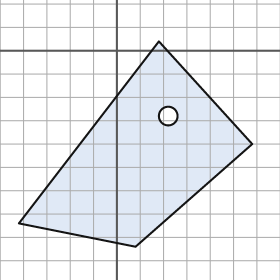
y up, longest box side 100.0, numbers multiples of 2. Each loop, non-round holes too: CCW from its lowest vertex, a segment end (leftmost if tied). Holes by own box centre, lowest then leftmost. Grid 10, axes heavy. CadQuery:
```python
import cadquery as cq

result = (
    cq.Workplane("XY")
    .moveTo(8.0, -84.0)
    .lineTo(58.0, -40.0)
    .lineTo(18.0, 4.0)
    .lineTo(-42.0, -74.0)
    .close()
    .moveTo(22.0, -28.0)
    .circle(4.0)
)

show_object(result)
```